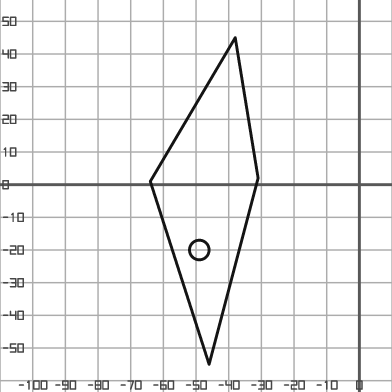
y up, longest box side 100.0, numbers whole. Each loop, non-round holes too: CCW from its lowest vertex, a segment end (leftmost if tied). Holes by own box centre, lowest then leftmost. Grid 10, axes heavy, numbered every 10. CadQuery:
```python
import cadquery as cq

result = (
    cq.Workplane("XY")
    .moveTo(-46.0, -55.0)
    .lineTo(-31.0, 2.0)
    .lineTo(-38.0, 45.0)
    .lineTo(-64.0, 1.0)
    .close()
    .moveTo(-49.0, -20.0)
    .circle(3.0)
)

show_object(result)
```